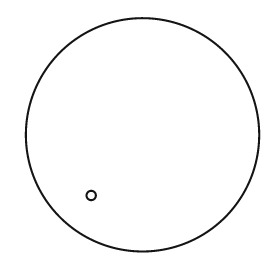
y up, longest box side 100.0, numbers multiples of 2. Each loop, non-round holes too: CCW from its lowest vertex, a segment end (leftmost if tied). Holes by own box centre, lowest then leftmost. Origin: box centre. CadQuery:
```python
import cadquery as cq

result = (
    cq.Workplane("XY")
    .moveTo(0.0, 0.0)
    .circle(50.0)
    .moveTo(-22.0, -26.0)
    .circle(2.0)
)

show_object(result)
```